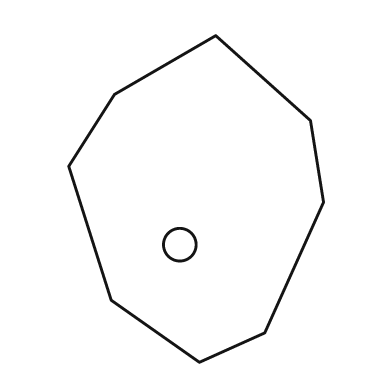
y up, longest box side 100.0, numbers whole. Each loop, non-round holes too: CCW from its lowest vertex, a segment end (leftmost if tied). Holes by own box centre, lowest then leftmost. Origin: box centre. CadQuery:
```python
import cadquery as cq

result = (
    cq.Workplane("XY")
    .moveTo(1.0, -50.0)
    .lineTo(21.0, -41.0)
    .lineTo(39.0, -1.0)
    .lineTo(35.0, 24.0)
    .lineTo(6.0, 50.0)
    .lineTo(-25.0, 32.0)
    .lineTo(-39.0, 10.0)
    .lineTo(-26.0, -31.0)
    .close()
    .moveTo(-5.0, -14.0)
    .circle(5.0)
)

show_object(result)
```